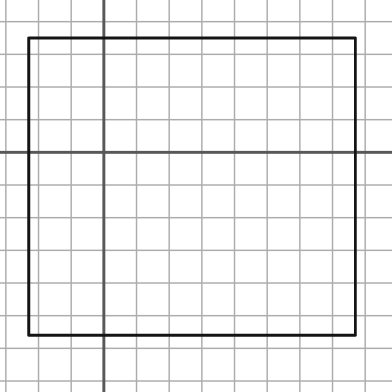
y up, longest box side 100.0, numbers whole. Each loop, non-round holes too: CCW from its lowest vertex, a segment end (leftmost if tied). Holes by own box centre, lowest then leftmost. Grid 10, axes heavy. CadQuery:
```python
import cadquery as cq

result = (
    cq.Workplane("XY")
    .moveTo(-23.0, -56.0)
    .lineTo(77.0, -56.0)
    .lineTo(77.0, 35.0)
    .lineTo(-23.0, 35.0)
    .close()
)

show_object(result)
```